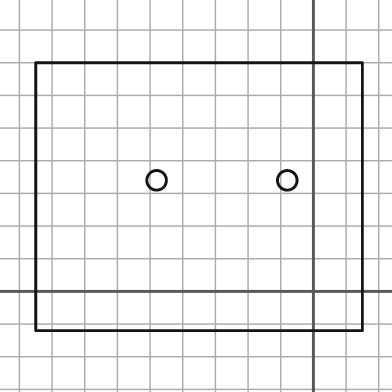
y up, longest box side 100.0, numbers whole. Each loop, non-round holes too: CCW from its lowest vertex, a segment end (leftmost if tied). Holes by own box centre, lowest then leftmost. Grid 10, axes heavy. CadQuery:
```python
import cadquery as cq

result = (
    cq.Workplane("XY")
    .moveTo(-85.0, -12.0)
    .lineTo(15.0, -12.0)
    .lineTo(15.0, 70.0)
    .lineTo(-85.0, 70.0)
    .close()
    .moveTo(-48.0, 34.0)
    .circle(3.0)
    .moveTo(-8.0, 34.0)
    .circle(3.0)
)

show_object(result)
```